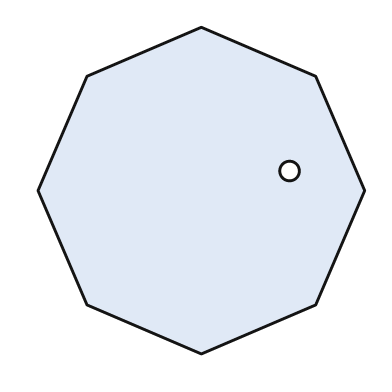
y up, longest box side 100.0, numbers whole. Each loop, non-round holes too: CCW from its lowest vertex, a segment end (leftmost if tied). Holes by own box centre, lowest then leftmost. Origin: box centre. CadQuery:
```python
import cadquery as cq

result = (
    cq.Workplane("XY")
    .moveTo(0.0, -50.0)
    .lineTo(35.0, -35.0)
    .lineTo(50.0, 0.0)
    .lineTo(35.0, 35.0)
    .lineTo(0.0, 50.0)
    .lineTo(-35.0, 35.0)
    .lineTo(-50.0, 0.0)
    .lineTo(-35.0, -35.0)
    .close()
    .moveTo(27.0, 6.0)
    .circle(3.0)
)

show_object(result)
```